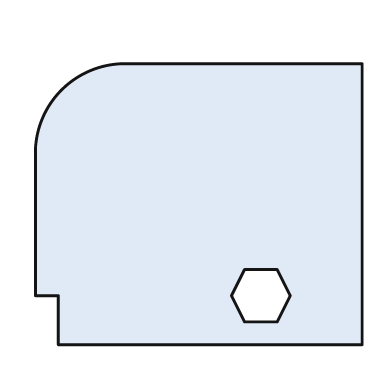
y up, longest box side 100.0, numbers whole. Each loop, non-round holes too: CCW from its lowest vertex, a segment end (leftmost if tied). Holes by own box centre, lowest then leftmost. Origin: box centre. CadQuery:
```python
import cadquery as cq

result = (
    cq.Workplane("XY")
    .moveTo(-43.0, -43.0)
    .lineTo(50.0, -43.0)
    .lineTo(50.0, 43.0)
    .lineTo(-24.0, 43.0)
    .threePointArc((-42.0, 35.0), (-50.0, 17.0))
    .lineTo(-50.0, -28.0)
    .lineTo(-43.0, -28.0)
    .close()
    .moveTo(14.0, -36.0)
    .lineTo(24.0, -36.0)
    .lineTo(28.0, -28.0)
    .lineTo(24.0, -20.0)
    .lineTo(14.0, -20.0)
    .lineTo(10.0, -28.0)
    .close()
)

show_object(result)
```